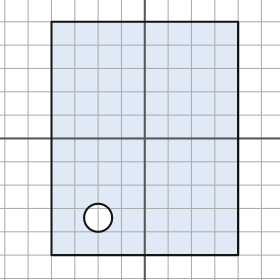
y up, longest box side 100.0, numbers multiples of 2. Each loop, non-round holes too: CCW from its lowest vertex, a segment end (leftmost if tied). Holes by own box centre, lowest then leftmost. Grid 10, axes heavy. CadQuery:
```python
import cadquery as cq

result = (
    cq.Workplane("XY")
    .moveTo(-40.0, -50.0)
    .lineTo(40.0, -50.0)
    .lineTo(40.0, 50.0)
    .lineTo(-40.0, 50.0)
    .close()
    .moveTo(-20.0, -34.0)
    .circle(6.0)
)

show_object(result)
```